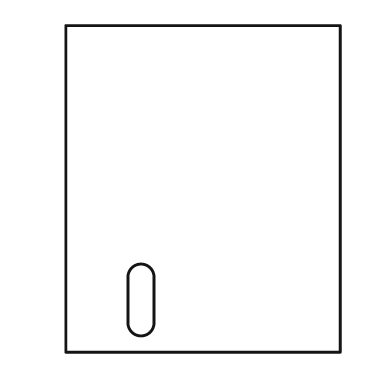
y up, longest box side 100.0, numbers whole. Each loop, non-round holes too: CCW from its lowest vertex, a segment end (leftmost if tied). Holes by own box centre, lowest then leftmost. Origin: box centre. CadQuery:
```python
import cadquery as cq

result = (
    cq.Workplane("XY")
    .moveTo(-42.0, -50.0)
    .lineTo(42.0, -50.0)
    .lineTo(42.0, 50.0)
    .lineTo(-42.0, 50.0)
    .close()
    .moveTo(-23.0, -41.0)
    .threePointArc((-19.0, -45.0), (-15.0, -41.0))
    .lineTo(-15.0, -27.0)
    .threePointArc((-19.0, -23.0), (-23.0, -27.0))
    .close()
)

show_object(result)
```